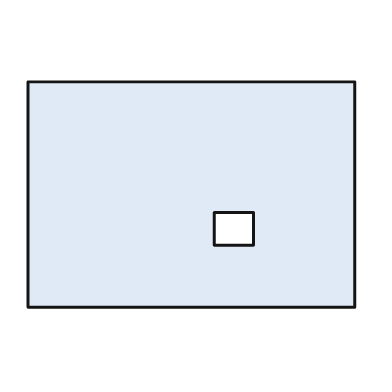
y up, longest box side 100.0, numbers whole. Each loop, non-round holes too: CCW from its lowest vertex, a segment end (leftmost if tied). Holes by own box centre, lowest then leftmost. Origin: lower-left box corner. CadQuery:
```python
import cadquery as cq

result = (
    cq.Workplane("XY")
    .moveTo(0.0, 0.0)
    .lineTo(100.0, 0.0)
    .lineTo(100.0, 69.0)
    .lineTo(0.0, 69.0)
    .close()
    .moveTo(57.0, 19.0)
    .lineTo(69.0, 19.0)
    .lineTo(69.0, 29.0)
    .lineTo(57.0, 29.0)
    .close()
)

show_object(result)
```